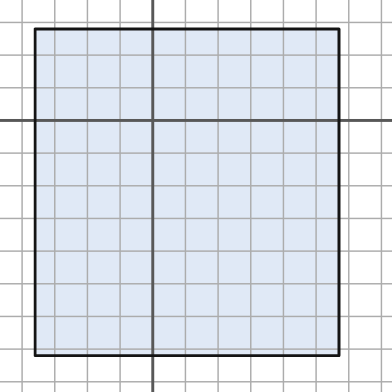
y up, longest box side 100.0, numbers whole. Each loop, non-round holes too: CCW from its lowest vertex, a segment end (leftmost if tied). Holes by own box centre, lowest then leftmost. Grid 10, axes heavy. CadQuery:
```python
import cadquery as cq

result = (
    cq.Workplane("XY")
    .moveTo(-36.0, -72.0)
    .lineTo(57.0, -72.0)
    .lineTo(57.0, 28.0)
    .lineTo(-36.0, 28.0)
    .close()
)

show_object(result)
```